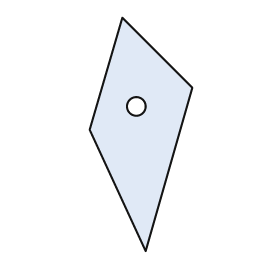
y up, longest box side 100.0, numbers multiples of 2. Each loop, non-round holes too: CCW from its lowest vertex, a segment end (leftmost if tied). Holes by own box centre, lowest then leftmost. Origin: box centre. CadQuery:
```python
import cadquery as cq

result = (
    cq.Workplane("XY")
    .moveTo(2.0, -50.0)
    .lineTo(22.0, 20.0)
    .lineTo(-8.0, 50.0)
    .lineTo(-22.0, 2.0)
    .close()
    .moveTo(-2.0, 12.0)
    .circle(4.0)
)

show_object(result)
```